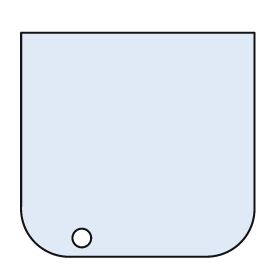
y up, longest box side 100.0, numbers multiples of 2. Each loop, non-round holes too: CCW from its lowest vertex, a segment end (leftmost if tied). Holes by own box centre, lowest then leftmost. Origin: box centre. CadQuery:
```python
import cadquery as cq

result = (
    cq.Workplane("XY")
    .moveTo(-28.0, -48.0)
    .lineTo(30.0, -48.0)
    .threePointArc((44.0, -42.0), (50.0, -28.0))
    .lineTo(50.0, 48.0)
    .lineTo(-50.0, 48.0)
    .lineTo(-50.0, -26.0)
    .threePointArc((-44.0, -42.0), (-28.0, -48.0))
    .close()
    .moveTo(-24.0, -40.0)
    .circle(4.0)
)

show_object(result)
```